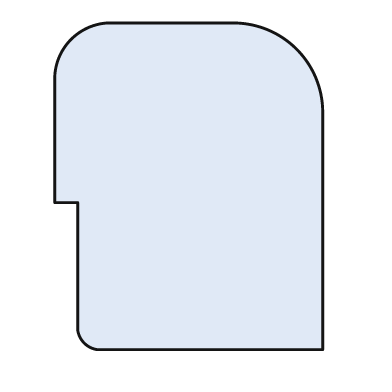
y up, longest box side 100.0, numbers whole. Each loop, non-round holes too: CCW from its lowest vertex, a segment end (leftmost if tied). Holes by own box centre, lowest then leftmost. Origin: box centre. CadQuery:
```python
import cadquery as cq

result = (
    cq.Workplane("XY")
    .moveTo(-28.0, -50.0)
    .lineTo(41.0, -50.0)
    .lineTo(41.0, 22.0)
    .threePointArc((33.0, 42.0), (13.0, 50.0))
    .lineTo(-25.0, 50.0)
    .threePointArc((-36.0, 45.0), (-41.0, 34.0))
    .lineTo(-41.0, -5.0)
    .lineTo(-34.0, -5.0)
    .lineTo(-34.0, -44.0)
    .threePointArc((-32.0, -48.0), (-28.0, -50.0))
    .close()
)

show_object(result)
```